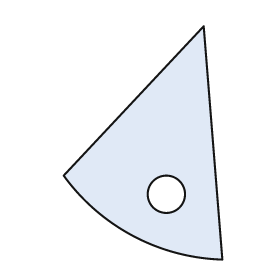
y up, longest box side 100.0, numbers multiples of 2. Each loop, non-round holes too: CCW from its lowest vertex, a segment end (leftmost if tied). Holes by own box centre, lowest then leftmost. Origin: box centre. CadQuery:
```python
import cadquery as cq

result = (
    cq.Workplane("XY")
    .moveTo(34.0, -50.0)
    .lineTo(26.0, 50.0)
    .lineTo(-34.0, -14.0)
    .threePointArc((-4.0, -40.0), (34.0, -50.0))
    .close()
    .moveTo(10.0, -22.0)
    .circle(8.0)
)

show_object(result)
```